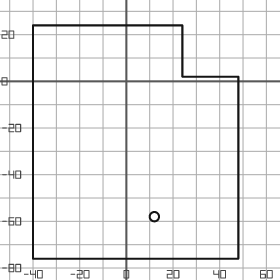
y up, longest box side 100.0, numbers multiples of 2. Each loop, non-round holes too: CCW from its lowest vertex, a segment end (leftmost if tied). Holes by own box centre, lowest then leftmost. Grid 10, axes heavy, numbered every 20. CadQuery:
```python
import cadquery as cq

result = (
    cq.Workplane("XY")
    .moveTo(-40.0, -76.0)
    .lineTo(48.0, -76.0)
    .lineTo(48.0, 2.0)
    .lineTo(24.0, 2.0)
    .lineTo(24.0, 24.0)
    .lineTo(-40.0, 24.0)
    .close()
    .moveTo(12.0, -58.0)
    .circle(2.0)
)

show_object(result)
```